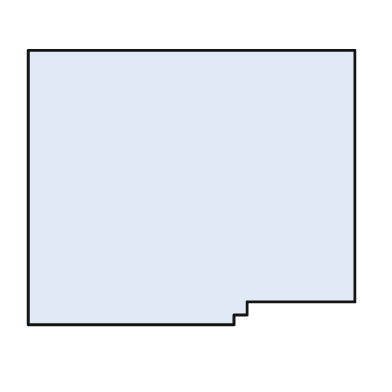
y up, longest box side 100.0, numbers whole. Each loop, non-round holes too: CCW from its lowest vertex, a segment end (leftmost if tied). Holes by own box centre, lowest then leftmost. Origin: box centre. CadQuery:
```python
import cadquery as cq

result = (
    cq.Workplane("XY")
    .moveTo(-50.0, -42.0)
    .lineTo(13.0, -42.0)
    .lineTo(13.0, -39.0)
    .lineTo(17.0, -39.0)
    .lineTo(17.0, -35.0)
    .lineTo(50.0, -35.0)
    .lineTo(50.0, 42.0)
    .lineTo(-50.0, 42.0)
    .close()
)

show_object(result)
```